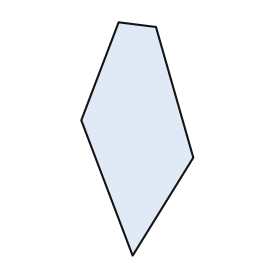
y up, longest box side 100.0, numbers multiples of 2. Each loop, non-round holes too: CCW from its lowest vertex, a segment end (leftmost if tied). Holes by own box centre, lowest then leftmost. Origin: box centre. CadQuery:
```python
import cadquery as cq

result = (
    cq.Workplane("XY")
    .moveTo(-2.0, -50.0)
    .lineTo(24.0, -8.0)
    .lineTo(8.0, 48.0)
    .lineTo(-8.0, 50.0)
    .lineTo(-24.0, 8.0)
    .close()
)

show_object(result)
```